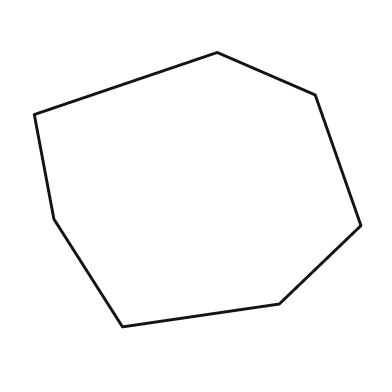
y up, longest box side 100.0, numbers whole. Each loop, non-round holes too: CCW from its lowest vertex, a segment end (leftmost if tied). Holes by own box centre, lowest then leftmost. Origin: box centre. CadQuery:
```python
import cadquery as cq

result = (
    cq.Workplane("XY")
    .moveTo(-23.0, -42.0)
    .lineTo(25.0, -35.0)
    .lineTo(50.0, -11.0)
    .lineTo(36.0, 29.0)
    .lineTo(6.0, 42.0)
    .lineTo(-50.0, 23.0)
    .lineTo(-44.0, -9.0)
    .close()
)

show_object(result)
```